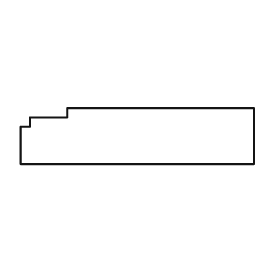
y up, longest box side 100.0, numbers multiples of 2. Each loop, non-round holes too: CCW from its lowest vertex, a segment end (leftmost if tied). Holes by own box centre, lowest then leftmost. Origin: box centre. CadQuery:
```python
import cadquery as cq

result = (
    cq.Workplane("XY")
    .moveTo(-50.0, -12.0)
    .lineTo(50.0, -12.0)
    .lineTo(50.0, 12.0)
    .lineTo(-30.0, 12.0)
    .lineTo(-30.0, 8.0)
    .lineTo(-46.0, 8.0)
    .lineTo(-46.0, 4.0)
    .lineTo(-50.0, 4.0)
    .close()
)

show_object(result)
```